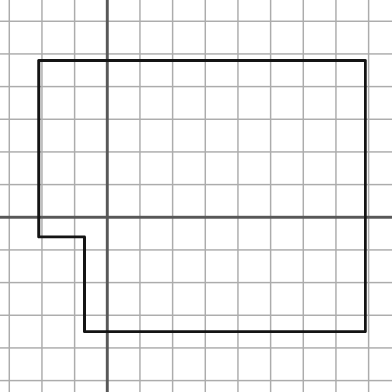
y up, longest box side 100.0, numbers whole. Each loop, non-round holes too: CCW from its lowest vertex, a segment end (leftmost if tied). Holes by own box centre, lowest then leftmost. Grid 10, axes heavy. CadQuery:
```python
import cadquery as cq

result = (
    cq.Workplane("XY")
    .moveTo(-7.0, -35.0)
    .lineTo(79.0, -35.0)
    .lineTo(79.0, 48.0)
    .lineTo(-21.0, 48.0)
    .lineTo(-21.0, -6.0)
    .lineTo(-7.0, -6.0)
    .close()
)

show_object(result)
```